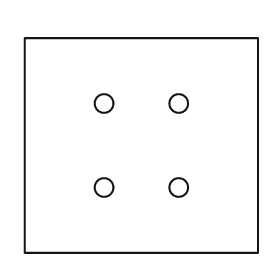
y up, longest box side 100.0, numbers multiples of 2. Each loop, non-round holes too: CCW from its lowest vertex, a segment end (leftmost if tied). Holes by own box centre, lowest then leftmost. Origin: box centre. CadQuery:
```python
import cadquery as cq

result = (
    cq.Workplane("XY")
    .moveTo(-50.0, -46.0)
    .lineTo(50.0, -46.0)
    .lineTo(50.0, 46.0)
    .lineTo(-50.0, 46.0)
    .close()
    .moveTo(-16.0, -18.0)
    .circle(4.0)
    .moveTo(16.0, -18.0)
    .circle(4.0)
    .moveTo(-16.0, 18.0)
    .circle(4.0)
    .moveTo(16.0, 18.0)
    .circle(4.0)
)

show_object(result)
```